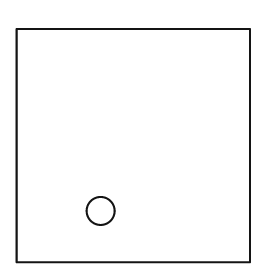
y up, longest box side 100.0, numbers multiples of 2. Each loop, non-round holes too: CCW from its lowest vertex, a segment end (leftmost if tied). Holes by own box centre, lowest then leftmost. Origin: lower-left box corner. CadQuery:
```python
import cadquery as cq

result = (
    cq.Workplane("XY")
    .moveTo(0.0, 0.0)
    .lineTo(100.0, 0.0)
    .lineTo(100.0, 100.0)
    .lineTo(0.0, 100.0)
    .close()
    .moveTo(36.0, 22.0)
    .circle(6.0)
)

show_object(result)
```